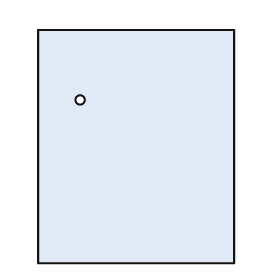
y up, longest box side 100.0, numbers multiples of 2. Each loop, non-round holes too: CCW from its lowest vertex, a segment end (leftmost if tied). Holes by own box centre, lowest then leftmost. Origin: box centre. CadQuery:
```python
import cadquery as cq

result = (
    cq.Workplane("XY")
    .moveTo(-42.0, -50.0)
    .lineTo(42.0, -50.0)
    .lineTo(42.0, 50.0)
    .lineTo(-42.0, 50.0)
    .close()
    .moveTo(-24.0, 20.0)
    .circle(2.0)
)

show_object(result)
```